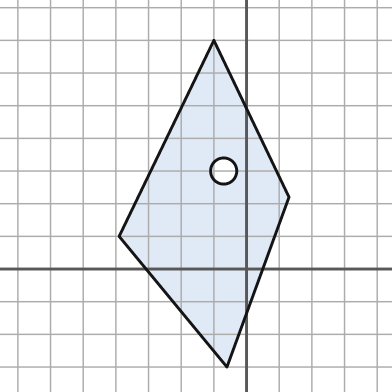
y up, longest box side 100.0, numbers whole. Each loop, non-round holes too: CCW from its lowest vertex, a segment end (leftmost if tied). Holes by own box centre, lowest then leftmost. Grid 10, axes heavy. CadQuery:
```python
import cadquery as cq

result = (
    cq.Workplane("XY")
    .moveTo(-6.0, -30.0)
    .lineTo(13.0, 22.0)
    .lineTo(-10.0, 70.0)
    .lineTo(-39.0, 10.0)
    .close()
    .moveTo(-7.0, 30.0)
    .circle(4.0)
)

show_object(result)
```